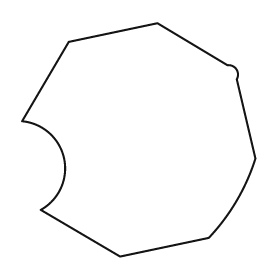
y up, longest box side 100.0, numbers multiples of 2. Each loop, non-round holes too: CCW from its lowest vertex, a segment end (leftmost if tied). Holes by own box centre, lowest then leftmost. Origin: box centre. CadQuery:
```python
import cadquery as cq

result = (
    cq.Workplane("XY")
    .moveTo(-8.0, -50.0)
    .lineTo(30.0, -42.0)
    .threePointArc((42.0, -26.0), (50.0, -8.0))
    .lineTo(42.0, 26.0)
    .threePointArc((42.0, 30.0), (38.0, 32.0))
    .lineTo(8.0, 50.0)
    .lineTo(-30.0, 42.0)
    .lineTo(-50.0, 8.0)
    .threePointArc((-32.0, -8.0), (-42.0, -30.0))
    .close()
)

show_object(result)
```